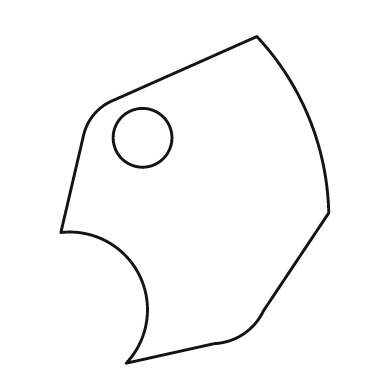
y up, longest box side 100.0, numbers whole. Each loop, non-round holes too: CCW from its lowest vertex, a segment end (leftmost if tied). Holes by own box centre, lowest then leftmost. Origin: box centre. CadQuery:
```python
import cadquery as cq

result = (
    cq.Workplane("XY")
    .moveTo(-21.0, -50.0)
    .lineTo(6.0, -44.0)
    .threePointArc((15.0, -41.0), (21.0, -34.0))
    .lineTo(41.0, -4.0)
    .threePointArc((35.0, 25.0), (19.0, 50.0))
    .lineTo(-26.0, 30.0)
    .threePointArc((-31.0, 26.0), (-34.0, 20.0))
    .lineTo(-41.0, -10.0)
    .threePointArc((-17.0, -23.0), (-21.0, -50.0))
    .close()
    .moveTo(-16.0, 19.0)
    .circle(9.0)
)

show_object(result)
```